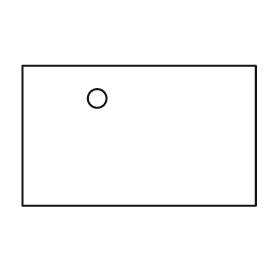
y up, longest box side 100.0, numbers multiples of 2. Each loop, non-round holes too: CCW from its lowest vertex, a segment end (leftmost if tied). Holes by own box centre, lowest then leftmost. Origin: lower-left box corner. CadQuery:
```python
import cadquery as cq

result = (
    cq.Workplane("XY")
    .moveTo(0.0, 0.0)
    .lineTo(100.0, 0.0)
    .lineTo(100.0, 60.0)
    .lineTo(0.0, 60.0)
    .close()
    .moveTo(32.0, 46.0)
    .circle(4.0)
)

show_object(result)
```